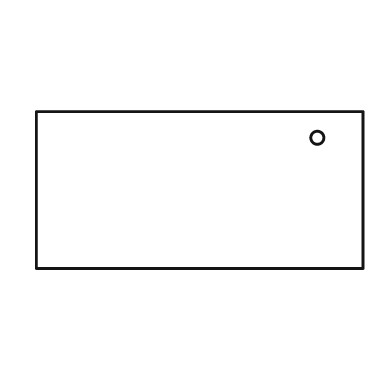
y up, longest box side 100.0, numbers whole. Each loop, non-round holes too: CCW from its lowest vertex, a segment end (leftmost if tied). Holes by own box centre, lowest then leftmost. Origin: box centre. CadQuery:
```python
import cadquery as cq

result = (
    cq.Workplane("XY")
    .moveTo(-50.0, -24.0)
    .lineTo(50.0, -24.0)
    .lineTo(50.0, 24.0)
    .lineTo(-50.0, 24.0)
    .close()
    .moveTo(36.0, 16.0)
    .circle(2.0)
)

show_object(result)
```